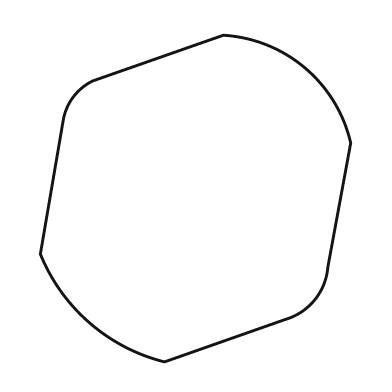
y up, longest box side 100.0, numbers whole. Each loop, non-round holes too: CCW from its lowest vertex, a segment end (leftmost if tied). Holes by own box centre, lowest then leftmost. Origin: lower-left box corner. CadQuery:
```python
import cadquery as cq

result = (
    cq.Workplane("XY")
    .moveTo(38.0, 0.0)
    .lineTo(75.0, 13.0)
    .threePointArc((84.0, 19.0), (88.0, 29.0))
    .lineTo(95.0, 67.0)
    .threePointArc((81.0, 90.0), (56.0, 100.0))
    .lineTo(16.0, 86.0)
    .threePointArc((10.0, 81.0), (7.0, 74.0))
    .lineTo(0.0, 33.0)
    .threePointArc((15.0, 12.0), (38.0, 0.0))
    .close()
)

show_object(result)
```